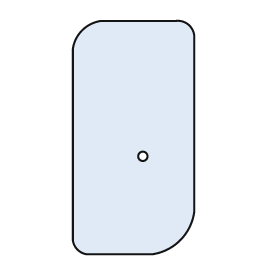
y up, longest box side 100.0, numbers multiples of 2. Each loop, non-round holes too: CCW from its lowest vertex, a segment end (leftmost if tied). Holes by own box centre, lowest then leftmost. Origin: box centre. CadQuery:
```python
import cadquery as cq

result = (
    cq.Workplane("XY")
    .moveTo(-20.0, -50.0)
    .lineTo(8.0, -50.0)
    .threePointArc((20.0, -44.0), (26.0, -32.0))
    .lineTo(26.0, 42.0)
    .threePointArc((24.0, 48.0), (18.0, 50.0))
    .lineTo(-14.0, 50.0)
    .threePointArc((-22.0, 46.0), (-26.0, 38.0))
    .lineTo(-26.0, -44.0)
    .threePointArc((-24.0, -48.0), (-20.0, -50.0))
    .close()
    .moveTo(4.0, -8.0)
    .circle(2.0)
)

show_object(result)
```